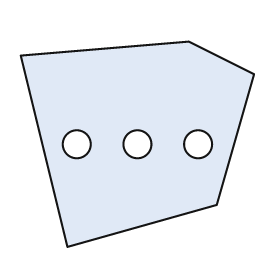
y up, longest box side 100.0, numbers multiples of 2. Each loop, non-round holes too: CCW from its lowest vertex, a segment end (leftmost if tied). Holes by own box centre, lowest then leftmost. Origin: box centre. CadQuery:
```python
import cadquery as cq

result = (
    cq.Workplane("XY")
    .moveTo(-30.0, -44.0)
    .lineTo(34.0, -26.0)
    .lineTo(50.0, 30.0)
    .lineTo(22.0, 44.0)
    .lineTo(-50.0, 38.0)
    .close()
    .moveTo(-26.0, 0.0)
    .circle(6.0)
    .moveTo(0.0, 0.0)
    .circle(6.0)
    .moveTo(26.0, 0.0)
    .circle(6.0)
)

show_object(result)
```